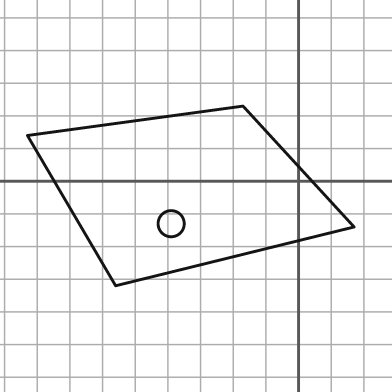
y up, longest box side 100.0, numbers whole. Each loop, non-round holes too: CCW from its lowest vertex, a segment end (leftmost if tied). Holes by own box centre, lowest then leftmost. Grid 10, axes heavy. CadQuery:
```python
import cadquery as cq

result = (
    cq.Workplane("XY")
    .moveTo(-56.0, -32.0)
    .lineTo(17.0, -14.0)
    .lineTo(-17.0, 23.0)
    .lineTo(-83.0, 14.0)
    .close()
    .moveTo(-39.0, -13.0)
    .circle(4.0)
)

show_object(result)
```